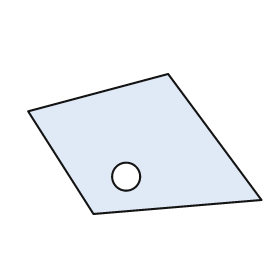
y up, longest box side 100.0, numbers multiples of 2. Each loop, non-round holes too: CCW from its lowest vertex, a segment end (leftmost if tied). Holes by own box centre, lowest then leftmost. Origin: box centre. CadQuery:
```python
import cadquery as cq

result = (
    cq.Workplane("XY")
    .moveTo(-22.0, -30.0)
    .lineTo(50.0, -24.0)
    .lineTo(10.0, 30.0)
    .lineTo(-50.0, 14.0)
    .close()
    .moveTo(-8.0, -14.0)
    .circle(6.0)
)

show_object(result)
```